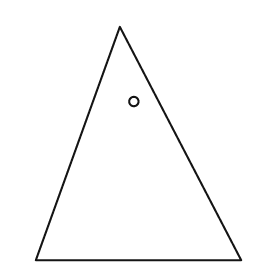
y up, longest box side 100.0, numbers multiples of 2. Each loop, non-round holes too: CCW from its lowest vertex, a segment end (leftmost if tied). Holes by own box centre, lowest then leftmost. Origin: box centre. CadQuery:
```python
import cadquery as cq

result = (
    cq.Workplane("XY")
    .moveTo(-44.0, -50.0)
    .lineTo(44.0, -50.0)
    .lineTo(-8.0, 50.0)
    .close()
    .moveTo(-2.0, 18.0)
    .circle(2.0)
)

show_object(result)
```